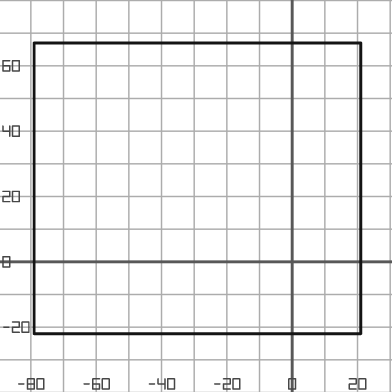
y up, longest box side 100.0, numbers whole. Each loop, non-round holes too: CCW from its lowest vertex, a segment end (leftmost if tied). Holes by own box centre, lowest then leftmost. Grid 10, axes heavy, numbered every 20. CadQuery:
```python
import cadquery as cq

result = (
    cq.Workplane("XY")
    .moveTo(-79.0, -22.0)
    .lineTo(21.0, -22.0)
    .lineTo(21.0, 67.0)
    .lineTo(-79.0, 67.0)
    .close()
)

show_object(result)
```